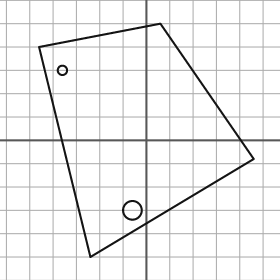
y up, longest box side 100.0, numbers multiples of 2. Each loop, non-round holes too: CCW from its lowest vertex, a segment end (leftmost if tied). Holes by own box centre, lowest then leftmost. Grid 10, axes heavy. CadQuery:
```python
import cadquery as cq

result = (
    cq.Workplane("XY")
    .moveTo(-24.0, -50.0)
    .lineTo(46.0, -8.0)
    .lineTo(6.0, 50.0)
    .lineTo(-46.0, 40.0)
    .close()
    .moveTo(-6.0, -30.0)
    .circle(4.0)
    .moveTo(-36.0, 30.0)
    .circle(2.0)
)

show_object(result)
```